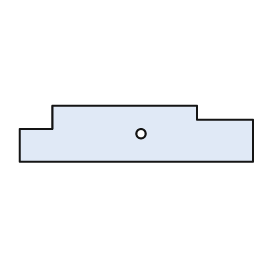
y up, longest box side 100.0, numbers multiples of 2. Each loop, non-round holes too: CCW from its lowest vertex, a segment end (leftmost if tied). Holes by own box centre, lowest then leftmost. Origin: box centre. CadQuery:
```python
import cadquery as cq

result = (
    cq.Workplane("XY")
    .moveTo(-50.0, -12.0)
    .lineTo(50.0, -12.0)
    .lineTo(50.0, 6.0)
    .lineTo(26.0, 6.0)
    .lineTo(26.0, 12.0)
    .lineTo(-36.0, 12.0)
    .lineTo(-36.0, 2.0)
    .lineTo(-50.0, 2.0)
    .close()
    .moveTo(2.0, 0.0)
    .circle(2.0)
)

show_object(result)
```